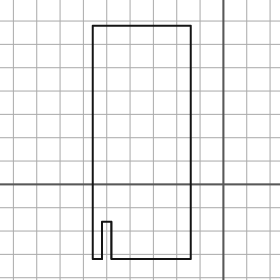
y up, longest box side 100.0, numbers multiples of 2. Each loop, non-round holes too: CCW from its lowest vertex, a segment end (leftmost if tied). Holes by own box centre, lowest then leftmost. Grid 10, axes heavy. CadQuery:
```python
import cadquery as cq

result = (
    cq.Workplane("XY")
    .moveTo(-56.0, -32.0)
    .lineTo(-52.0, -32.0)
    .lineTo(-52.0, -16.0)
    .lineTo(-48.0, -16.0)
    .lineTo(-48.0, -32.0)
    .lineTo(-14.0, -32.0)
    .lineTo(-14.0, 68.0)
    .lineTo(-56.0, 68.0)
    .close()
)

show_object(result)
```